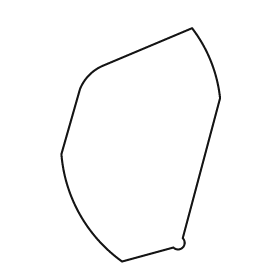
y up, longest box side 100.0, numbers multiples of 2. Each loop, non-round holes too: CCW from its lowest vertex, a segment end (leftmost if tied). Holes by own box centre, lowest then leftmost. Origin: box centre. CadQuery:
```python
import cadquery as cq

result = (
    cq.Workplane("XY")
    .moveTo(-8.0, -50.0)
    .lineTo(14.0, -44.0)
    .threePointArc((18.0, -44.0), (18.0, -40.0))
    .lineTo(34.0, 20.0)
    .threePointArc((30.0, 36.0), (22.0, 50.0))
    .lineTo(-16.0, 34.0)
    .threePointArc((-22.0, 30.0), (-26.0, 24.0))
    .lineTo(-34.0, -4.0)
    .threePointArc((-26.0, -30.0), (-8.0, -50.0))
    .close()
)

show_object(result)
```